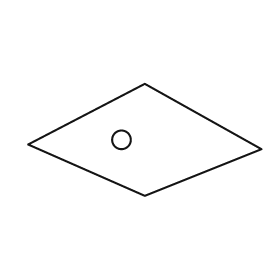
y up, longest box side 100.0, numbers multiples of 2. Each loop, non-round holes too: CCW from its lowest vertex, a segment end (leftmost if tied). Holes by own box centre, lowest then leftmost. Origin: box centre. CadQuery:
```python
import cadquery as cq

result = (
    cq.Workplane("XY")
    .moveTo(0.0, -24.0)
    .lineTo(50.0, -4.0)
    .lineTo(0.0, 24.0)
    .lineTo(-50.0, -2.0)
    .close()
    .moveTo(-10.0, 0.0)
    .circle(4.0)
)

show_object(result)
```